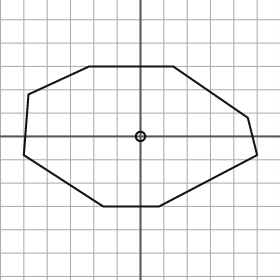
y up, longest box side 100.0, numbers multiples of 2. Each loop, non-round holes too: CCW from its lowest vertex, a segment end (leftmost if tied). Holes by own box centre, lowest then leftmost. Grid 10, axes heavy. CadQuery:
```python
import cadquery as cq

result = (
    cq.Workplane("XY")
    .moveTo(-16.0, -30.0)
    .lineTo(8.0, -30.0)
    .lineTo(50.0, -8.0)
    .lineTo(46.0, 8.0)
    .lineTo(14.0, 30.0)
    .lineTo(-22.0, 30.0)
    .lineTo(-48.0, 18.0)
    .lineTo(-50.0, -8.0)
    .close()
    .moveTo(0.0, 0.0)
    .circle(2.0)
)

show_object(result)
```